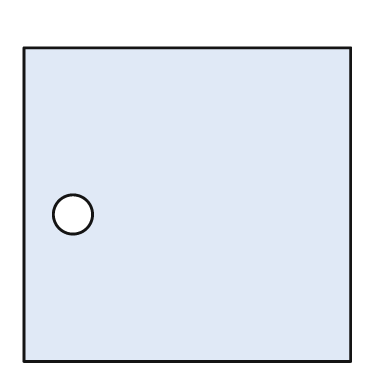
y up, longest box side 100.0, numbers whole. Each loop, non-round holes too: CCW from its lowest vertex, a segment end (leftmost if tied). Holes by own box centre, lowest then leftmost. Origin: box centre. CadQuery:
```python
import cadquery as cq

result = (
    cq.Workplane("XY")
    .moveTo(-50.0, -48.0)
    .lineTo(50.0, -48.0)
    .lineTo(50.0, 48.0)
    .lineTo(-50.0, 48.0)
    .close()
    .moveTo(-35.0, -3.0)
    .circle(6.0)
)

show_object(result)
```